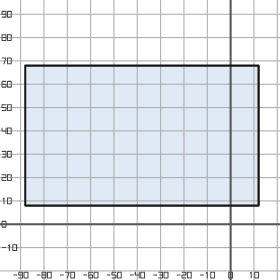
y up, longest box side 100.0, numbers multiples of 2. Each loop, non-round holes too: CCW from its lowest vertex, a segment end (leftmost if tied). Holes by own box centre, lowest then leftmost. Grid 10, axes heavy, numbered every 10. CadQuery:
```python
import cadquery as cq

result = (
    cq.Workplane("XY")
    .moveTo(-88.0, 8.0)
    .lineTo(12.0, 8.0)
    .lineTo(12.0, 68.0)
    .lineTo(-88.0, 68.0)
    .close()
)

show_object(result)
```